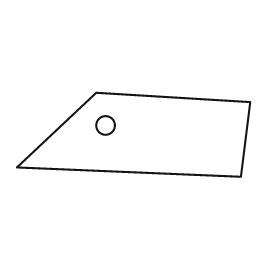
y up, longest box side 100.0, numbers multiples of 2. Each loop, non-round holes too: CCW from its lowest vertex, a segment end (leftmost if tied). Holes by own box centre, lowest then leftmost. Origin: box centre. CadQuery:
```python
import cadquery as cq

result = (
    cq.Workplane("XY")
    .moveTo(46.0, -18.0)
    .lineTo(50.0, 14.0)
    .lineTo(-16.0, 18.0)
    .lineTo(-50.0, -14.0)
    .close()
    .moveTo(-12.0, 4.0)
    .circle(4.0)
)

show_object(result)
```